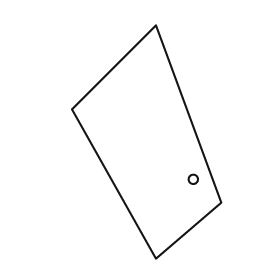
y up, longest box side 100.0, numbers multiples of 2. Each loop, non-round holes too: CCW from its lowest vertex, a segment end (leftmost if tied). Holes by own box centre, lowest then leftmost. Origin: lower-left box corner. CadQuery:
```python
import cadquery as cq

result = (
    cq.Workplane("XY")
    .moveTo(36.0, 0.0)
    .lineTo(64.0, 24.0)
    .lineTo(36.0, 100.0)
    .lineTo(0.0, 64.0)
    .close()
    .moveTo(52.0, 34.0)
    .circle(2.0)
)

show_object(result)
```